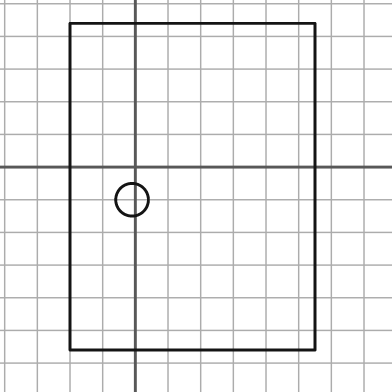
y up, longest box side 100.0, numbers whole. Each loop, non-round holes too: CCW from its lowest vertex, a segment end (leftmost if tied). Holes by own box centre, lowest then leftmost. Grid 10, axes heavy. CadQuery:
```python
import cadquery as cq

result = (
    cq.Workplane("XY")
    .moveTo(-20.0, -56.0)
    .lineTo(55.0, -56.0)
    .lineTo(55.0, 44.0)
    .lineTo(-20.0, 44.0)
    .close()
    .moveTo(-1.0, -10.0)
    .circle(5.0)
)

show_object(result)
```